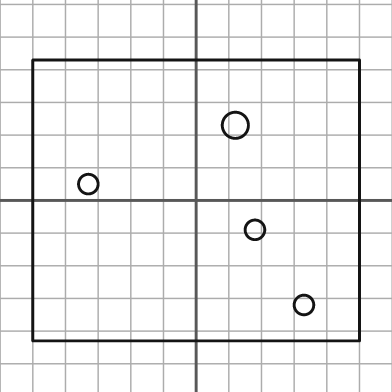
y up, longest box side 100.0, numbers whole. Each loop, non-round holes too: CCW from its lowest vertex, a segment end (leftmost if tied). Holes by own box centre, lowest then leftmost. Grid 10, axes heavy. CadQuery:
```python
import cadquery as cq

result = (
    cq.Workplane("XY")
    .moveTo(-50.0, -43.0)
    .lineTo(50.0, -43.0)
    .lineTo(50.0, 43.0)
    .lineTo(-50.0, 43.0)
    .close()
    .moveTo(33.0, -32.0)
    .circle(3.0)
    .moveTo(18.0, -9.0)
    .circle(3.0)
    .moveTo(-33.0, 5.0)
    .circle(3.0)
    .moveTo(12.0, 23.0)
    .circle(4.0)
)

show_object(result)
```